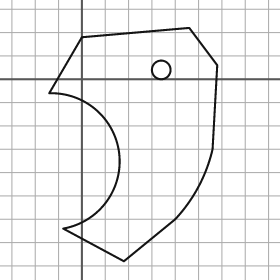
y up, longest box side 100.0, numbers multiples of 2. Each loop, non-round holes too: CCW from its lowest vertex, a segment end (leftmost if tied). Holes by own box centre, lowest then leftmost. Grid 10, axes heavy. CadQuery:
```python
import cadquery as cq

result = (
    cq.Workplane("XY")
    .moveTo(18.0, -78.0)
    .lineTo(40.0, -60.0)
    .threePointArc((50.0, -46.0), (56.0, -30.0))
    .lineTo(58.0, 6.0)
    .lineTo(46.0, 22.0)
    .lineTo(0.0, 18.0)
    .lineTo(-14.0, -6.0)
    .threePointArc((16.0, -32.0), (-8.0, -64.0))
    .close()
    .moveTo(34.0, 4.0)
    .circle(4.0)
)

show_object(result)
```